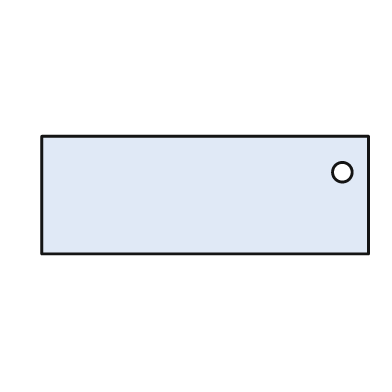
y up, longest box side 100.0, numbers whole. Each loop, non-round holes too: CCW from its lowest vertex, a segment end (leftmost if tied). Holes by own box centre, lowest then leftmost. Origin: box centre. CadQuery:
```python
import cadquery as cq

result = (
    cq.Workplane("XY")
    .moveTo(-50.0, -18.0)
    .lineTo(50.0, -18.0)
    .lineTo(50.0, 18.0)
    .lineTo(-50.0, 18.0)
    .close()
    .moveTo(42.0, 7.0)
    .circle(3.0)
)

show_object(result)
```